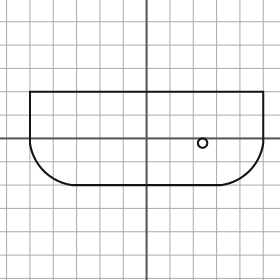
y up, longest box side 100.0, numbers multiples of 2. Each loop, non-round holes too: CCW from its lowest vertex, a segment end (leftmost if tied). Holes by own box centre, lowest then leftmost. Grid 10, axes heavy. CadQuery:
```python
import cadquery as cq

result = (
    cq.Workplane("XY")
    .moveTo(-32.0, -20.0)
    .lineTo(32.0, -20.0)
    .threePointArc((44.0, -14.0), (50.0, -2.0))
    .lineTo(50.0, 20.0)
    .lineTo(-50.0, 20.0)
    .lineTo(-50.0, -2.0)
    .threePointArc((-44.0, -14.0), (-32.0, -20.0))
    .close()
    .moveTo(24.0, -2.0)
    .circle(2.0)
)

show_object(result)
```